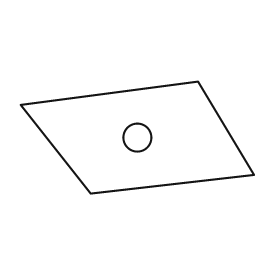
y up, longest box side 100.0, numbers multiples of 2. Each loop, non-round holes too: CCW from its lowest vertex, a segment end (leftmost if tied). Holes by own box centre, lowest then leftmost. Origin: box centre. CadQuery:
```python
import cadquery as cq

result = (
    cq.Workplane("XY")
    .moveTo(-20.0, -24.0)
    .lineTo(50.0, -16.0)
    .lineTo(26.0, 24.0)
    .lineTo(-50.0, 14.0)
    .close()
    .moveTo(0.0, 0.0)
    .circle(6.0)
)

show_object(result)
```